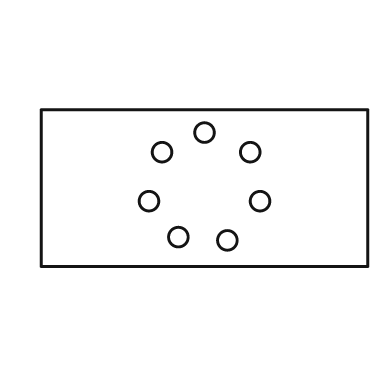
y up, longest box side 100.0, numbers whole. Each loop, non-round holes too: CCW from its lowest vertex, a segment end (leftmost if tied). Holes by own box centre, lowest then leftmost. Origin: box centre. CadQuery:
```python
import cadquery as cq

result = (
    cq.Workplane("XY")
    .moveTo(-50.0, -24.0)
    .lineTo(50.0, -24.0)
    .lineTo(50.0, 24.0)
    .lineTo(-50.0, 24.0)
    .close()
    .moveTo(7.0, -16.0)
    .circle(3.0)
    .moveTo(-8.0, -15.0)
    .circle(3.0)
    .moveTo(-17.0, -4.0)
    .circle(3.0)
    .moveTo(17.0, -4.0)
    .circle(3.0)
    .moveTo(-13.0, 11.0)
    .circle(3.0)
    .moveTo(14.0, 11.0)
    .circle(3.0)
    .moveTo(0.0, 17.0)
    .circle(3.0)
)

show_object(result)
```